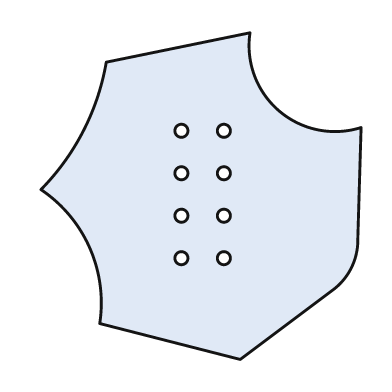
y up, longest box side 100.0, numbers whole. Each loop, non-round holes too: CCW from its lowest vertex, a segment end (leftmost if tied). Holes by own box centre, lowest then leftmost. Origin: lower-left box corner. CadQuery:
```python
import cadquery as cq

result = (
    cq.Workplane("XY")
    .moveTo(61.0, 0.0)
    .lineTo(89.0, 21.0)
    .threePointArc((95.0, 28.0), (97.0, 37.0))
    .lineTo(98.0, 71.0)
    .threePointArc((73.0, 76.0), (64.0, 100.0))
    .lineTo(20.0, 91.0)
    .threePointArc((13.0, 70.0), (0.0, 52.0))
    .threePointArc((15.0, 34.0), (18.0, 11.0))
    .close()
    .moveTo(43.0, 31.0)
    .circle(2.0)
    .moveTo(56.0, 31.0)
    .circle(2.0)
    .moveTo(43.0, 44.0)
    .circle(2.0)
    .moveTo(56.0, 44.0)
    .circle(2.0)
    .moveTo(43.0, 57.0)
    .circle(2.0)
    .moveTo(56.0, 57.0)
    .circle(2.0)
    .moveTo(43.0, 70.0)
    .circle(2.0)
    .moveTo(56.0, 70.0)
    .circle(2.0)
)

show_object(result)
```